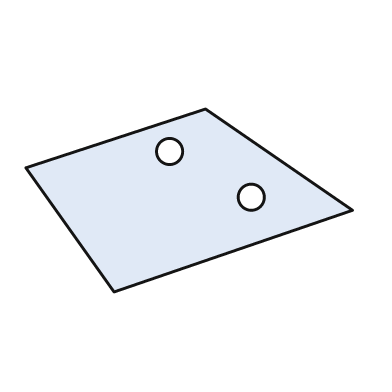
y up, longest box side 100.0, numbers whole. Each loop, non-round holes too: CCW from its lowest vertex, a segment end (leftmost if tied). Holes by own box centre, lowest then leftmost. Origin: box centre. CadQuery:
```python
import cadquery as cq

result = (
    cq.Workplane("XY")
    .moveTo(-23.0, -28.0)
    .lineTo(50.0, -3.0)
    .lineTo(5.0, 28.0)
    .lineTo(-50.0, 10.0)
    .close()
    .moveTo(19.0, 1.0)
    .circle(4.0)
    .moveTo(-6.0, 15.0)
    .circle(4.0)
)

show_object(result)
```